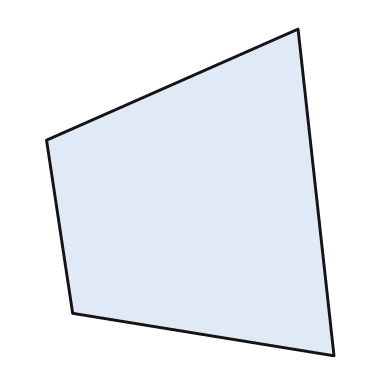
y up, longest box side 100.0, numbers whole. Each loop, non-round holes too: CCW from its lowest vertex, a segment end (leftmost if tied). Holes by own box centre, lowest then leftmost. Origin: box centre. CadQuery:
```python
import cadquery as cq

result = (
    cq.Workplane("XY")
    .moveTo(44.0, -50.0)
    .lineTo(33.0, 50.0)
    .lineTo(-44.0, 16.0)
    .lineTo(-36.0, -37.0)
    .close()
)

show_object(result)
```